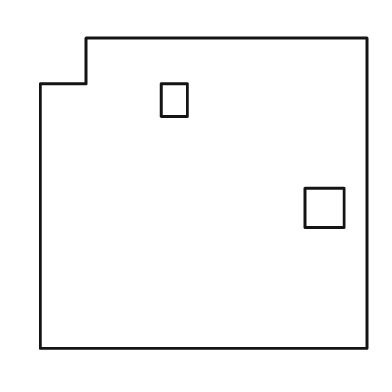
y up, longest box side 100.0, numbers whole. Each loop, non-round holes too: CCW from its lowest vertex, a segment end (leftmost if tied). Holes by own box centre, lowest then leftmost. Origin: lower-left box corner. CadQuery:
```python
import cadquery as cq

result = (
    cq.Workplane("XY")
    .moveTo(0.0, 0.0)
    .lineTo(100.0, 0.0)
    .lineTo(100.0, 95.0)
    .lineTo(14.0, 95.0)
    .lineTo(14.0, 81.0)
    .lineTo(0.0, 81.0)
    .close()
    .moveTo(81.0, 37.0)
    .lineTo(93.0, 37.0)
    .lineTo(93.0, 49.0)
    .lineTo(81.0, 49.0)
    .close()
    .moveTo(37.0, 71.0)
    .lineTo(45.0, 71.0)
    .lineTo(45.0, 81.0)
    .lineTo(37.0, 81.0)
    .close()
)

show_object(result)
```